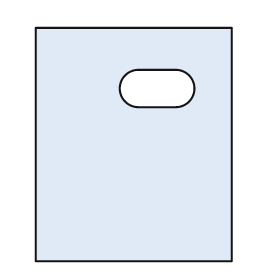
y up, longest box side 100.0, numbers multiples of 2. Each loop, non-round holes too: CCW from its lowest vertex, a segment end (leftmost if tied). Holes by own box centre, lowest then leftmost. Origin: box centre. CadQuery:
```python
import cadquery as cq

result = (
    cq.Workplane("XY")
    .moveTo(-42.0, -50.0)
    .lineTo(42.0, -50.0)
    .lineTo(42.0, 50.0)
    .lineTo(-42.0, 50.0)
    .close()
    .moveTo(2.0, 16.0)
    .lineTo(18.0, 16.0)
    .threePointArc((26.0, 24.0), (18.0, 32.0))
    .lineTo(2.0, 32.0)
    .threePointArc((-6.0, 24.0), (2.0, 16.0))
    .close()
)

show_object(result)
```